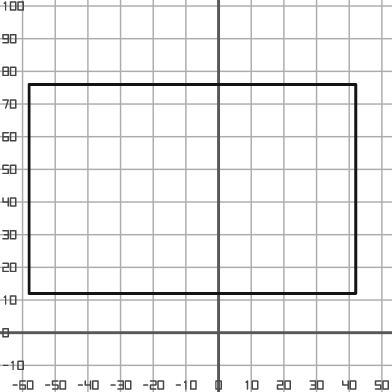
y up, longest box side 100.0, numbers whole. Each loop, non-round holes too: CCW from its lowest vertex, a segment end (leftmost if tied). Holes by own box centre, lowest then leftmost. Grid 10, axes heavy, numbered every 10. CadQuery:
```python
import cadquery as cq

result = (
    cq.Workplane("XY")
    .moveTo(-58.0, 12.0)
    .lineTo(42.0, 12.0)
    .lineTo(42.0, 76.0)
    .lineTo(-58.0, 76.0)
    .close()
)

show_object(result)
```